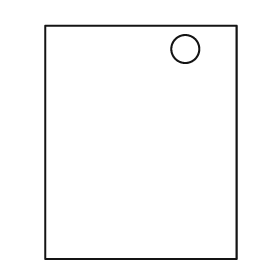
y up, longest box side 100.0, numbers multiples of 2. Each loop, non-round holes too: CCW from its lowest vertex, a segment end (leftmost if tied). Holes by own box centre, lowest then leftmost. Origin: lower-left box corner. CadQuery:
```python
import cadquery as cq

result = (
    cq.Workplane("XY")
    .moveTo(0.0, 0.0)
    .lineTo(82.0, 0.0)
    .lineTo(82.0, 100.0)
    .lineTo(0.0, 100.0)
    .close()
    .moveTo(60.0, 90.0)
    .circle(6.0)
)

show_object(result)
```